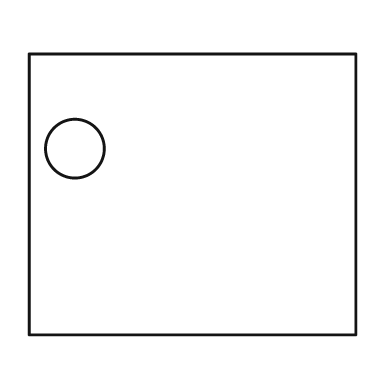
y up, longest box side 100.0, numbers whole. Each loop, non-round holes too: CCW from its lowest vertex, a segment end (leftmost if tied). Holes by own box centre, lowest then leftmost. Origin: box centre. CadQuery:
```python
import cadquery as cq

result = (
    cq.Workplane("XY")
    .moveTo(-50.0, -43.0)
    .lineTo(50.0, -43.0)
    .lineTo(50.0, 43.0)
    .lineTo(-50.0, 43.0)
    .close()
    .moveTo(-36.0, 14.0)
    .circle(9.0)
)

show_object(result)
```